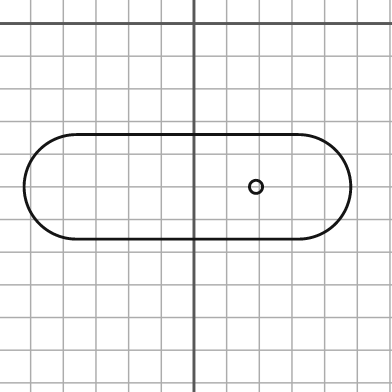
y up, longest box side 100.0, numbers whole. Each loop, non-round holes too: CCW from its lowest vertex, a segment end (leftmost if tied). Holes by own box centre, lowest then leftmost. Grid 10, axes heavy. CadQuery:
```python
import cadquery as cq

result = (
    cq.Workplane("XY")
    .moveTo(-36.0, -66.0)
    .lineTo(32.0, -66.0)
    .threePointArc((48.0, -50.0), (32.0, -34.0))
    .lineTo(-36.0, -34.0)
    .threePointArc((-52.0, -50.0), (-36.0, -66.0))
    .close()
    .moveTo(19.0, -50.0)
    .circle(2.0)
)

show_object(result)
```